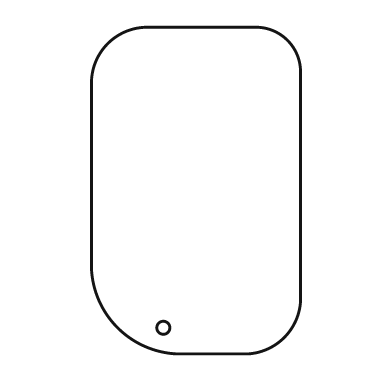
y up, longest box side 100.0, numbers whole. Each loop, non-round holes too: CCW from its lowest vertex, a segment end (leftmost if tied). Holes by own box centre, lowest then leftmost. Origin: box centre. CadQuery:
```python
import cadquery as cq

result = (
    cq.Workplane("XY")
    .moveTo(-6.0, -50.0)
    .lineTo(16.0, -50.0)
    .threePointArc((27.0, -45.0), (32.0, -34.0))
    .lineTo(32.0, 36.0)
    .threePointArc((28.0, 46.0), (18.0, 50.0))
    .lineTo(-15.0, 50.0)
    .threePointArc((-27.0, 45.0), (-32.0, 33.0))
    .lineTo(-32.0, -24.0)
    .threePointArc((-24.0, -42.0), (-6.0, -50.0))
    .close()
    .moveTo(-10.0, -42.0)
    .circle(2.0)
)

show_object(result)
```